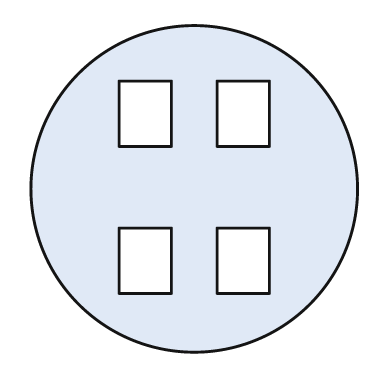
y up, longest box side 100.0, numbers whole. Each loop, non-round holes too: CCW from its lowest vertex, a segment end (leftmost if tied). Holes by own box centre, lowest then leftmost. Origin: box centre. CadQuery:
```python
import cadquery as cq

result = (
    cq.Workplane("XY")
    .moveTo(0.0, 0.0)
    .circle(50.0)
    .moveTo(-23.0, -32.0)
    .lineTo(-7.0, -32.0)
    .lineTo(-7.0, -12.0)
    .lineTo(-23.0, -12.0)
    .close()
    .moveTo(7.0, -32.0)
    .lineTo(23.0, -32.0)
    .lineTo(23.0, -12.0)
    .lineTo(7.0, -12.0)
    .close()
    .moveTo(-23.0, 13.0)
    .lineTo(-7.0, 13.0)
    .lineTo(-7.0, 33.0)
    .lineTo(-23.0, 33.0)
    .close()
    .moveTo(7.0, 13.0)
    .lineTo(23.0, 13.0)
    .lineTo(23.0, 33.0)
    .lineTo(7.0, 33.0)
    .close()
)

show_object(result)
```